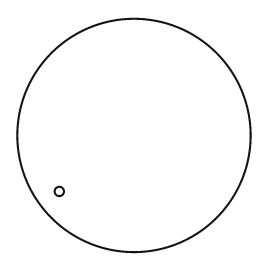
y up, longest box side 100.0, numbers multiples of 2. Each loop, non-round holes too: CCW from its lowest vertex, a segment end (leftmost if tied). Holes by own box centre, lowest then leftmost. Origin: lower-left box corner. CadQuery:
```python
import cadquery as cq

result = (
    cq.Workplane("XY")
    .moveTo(50.0, 50.0)
    .circle(50.0)
    .moveTo(18.0, 26.0)
    .circle(2.0)
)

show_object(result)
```